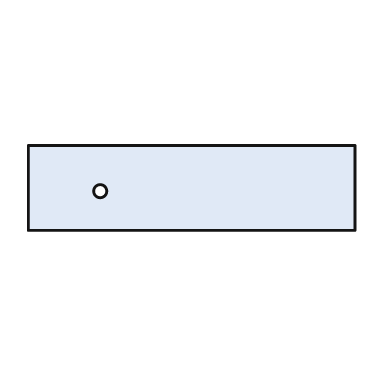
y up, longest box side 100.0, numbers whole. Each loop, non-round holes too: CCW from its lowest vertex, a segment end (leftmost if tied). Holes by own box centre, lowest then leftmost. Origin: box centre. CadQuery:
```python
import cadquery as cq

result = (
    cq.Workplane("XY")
    .moveTo(-50.0, -13.0)
    .lineTo(50.0, -13.0)
    .lineTo(50.0, 13.0)
    .lineTo(-50.0, 13.0)
    .close()
    .moveTo(-28.0, -1.0)
    .circle(2.0)
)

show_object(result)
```